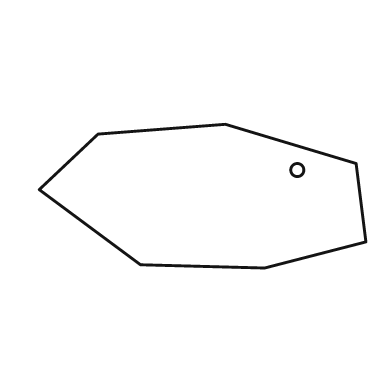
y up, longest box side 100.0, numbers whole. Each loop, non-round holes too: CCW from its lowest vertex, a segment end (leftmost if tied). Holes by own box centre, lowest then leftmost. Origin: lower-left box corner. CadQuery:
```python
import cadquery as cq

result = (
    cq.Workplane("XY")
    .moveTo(69.0, 0.0)
    .lineTo(100.0, 8.0)
    .lineTo(97.0, 32.0)
    .lineTo(57.0, 44.0)
    .lineTo(18.0, 41.0)
    .lineTo(0.0, 24.0)
    .lineTo(31.0, 1.0)
    .close()
    .moveTo(79.0, 30.0)
    .circle(2.0)
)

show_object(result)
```